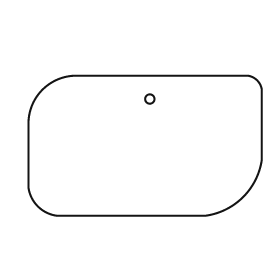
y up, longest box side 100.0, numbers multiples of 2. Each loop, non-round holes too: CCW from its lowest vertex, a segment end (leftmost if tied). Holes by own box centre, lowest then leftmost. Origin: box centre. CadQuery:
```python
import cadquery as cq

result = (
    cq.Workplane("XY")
    .moveTo(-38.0, -30.0)
    .lineTo(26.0, -30.0)
    .threePointArc((42.0, -22.0), (50.0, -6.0))
    .lineTo(50.0, 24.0)
    .threePointArc((48.0, 28.0), (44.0, 30.0))
    .lineTo(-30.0, 30.0)
    .threePointArc((-44.0, 24.0), (-50.0, 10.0))
    .lineTo(-50.0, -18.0)
    .threePointArc((-46.0, -26.0), (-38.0, -30.0))
    .close()
    .moveTo(2.0, 20.0)
    .circle(2.0)
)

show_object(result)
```